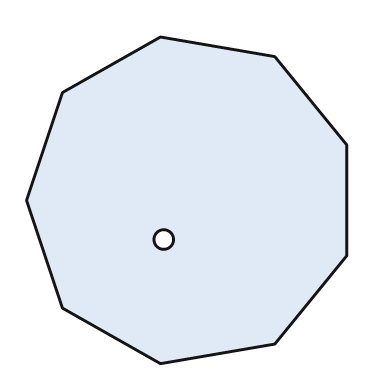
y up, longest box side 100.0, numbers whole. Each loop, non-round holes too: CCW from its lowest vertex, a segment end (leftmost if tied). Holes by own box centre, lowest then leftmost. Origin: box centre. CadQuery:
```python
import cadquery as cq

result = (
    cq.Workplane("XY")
    .moveTo(-8.0, -50.0)
    .lineTo(27.0, -44.0)
    .lineTo(49.0, -17.0)
    .lineTo(49.0, 17.0)
    .lineTo(27.0, 44.0)
    .lineTo(-8.0, 50.0)
    .lineTo(-38.0, 33.0)
    .lineTo(-49.0, 0.0)
    .lineTo(-38.0, -33.0)
    .close()
    .moveTo(-7.0, -12.0)
    .circle(3.0)
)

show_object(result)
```